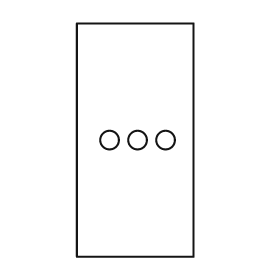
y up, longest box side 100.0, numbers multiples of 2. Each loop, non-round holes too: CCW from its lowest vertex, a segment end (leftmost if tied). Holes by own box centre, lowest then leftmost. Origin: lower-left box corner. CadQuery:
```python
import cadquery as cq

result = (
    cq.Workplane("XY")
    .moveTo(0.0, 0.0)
    .lineTo(50.0, 0.0)
    .lineTo(50.0, 100.0)
    .lineTo(0.0, 100.0)
    .close()
    .moveTo(14.0, 50.0)
    .circle(4.0)
    .moveTo(26.0, 50.0)
    .circle(4.0)
    .moveTo(38.0, 50.0)
    .circle(4.0)
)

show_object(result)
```